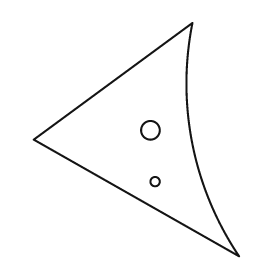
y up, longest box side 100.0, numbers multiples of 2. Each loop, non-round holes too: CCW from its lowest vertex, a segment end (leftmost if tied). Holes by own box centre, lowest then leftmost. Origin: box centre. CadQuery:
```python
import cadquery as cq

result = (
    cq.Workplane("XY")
    .moveTo(44.0, -50.0)
    .threePointArc((24.0, -2.0), (24.0, 50.0))
    .lineTo(-44.0, 0.0)
    .close()
    .moveTo(8.0, -18.0)
    .circle(2.0)
    .moveTo(6.0, 4.0)
    .circle(4.0)
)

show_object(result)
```